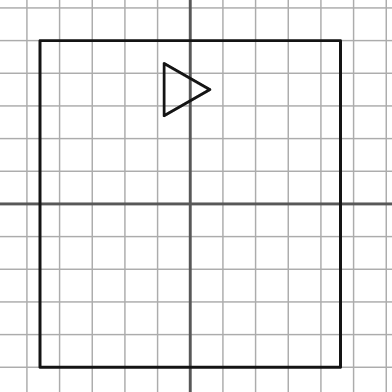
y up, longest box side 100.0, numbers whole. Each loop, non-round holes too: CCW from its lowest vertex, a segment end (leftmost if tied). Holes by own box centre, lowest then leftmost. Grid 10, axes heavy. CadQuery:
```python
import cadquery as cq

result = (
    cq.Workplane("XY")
    .moveTo(-46.0, -50.0)
    .lineTo(46.0, -50.0)
    .lineTo(46.0, 50.0)
    .lineTo(-46.0, 50.0)
    .close()
    .moveTo(-8.0, 27.0)
    .lineTo(6.0, 35.0)
    .lineTo(-8.0, 43.0)
    .close()
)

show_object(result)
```